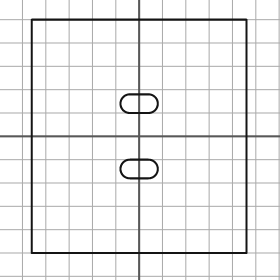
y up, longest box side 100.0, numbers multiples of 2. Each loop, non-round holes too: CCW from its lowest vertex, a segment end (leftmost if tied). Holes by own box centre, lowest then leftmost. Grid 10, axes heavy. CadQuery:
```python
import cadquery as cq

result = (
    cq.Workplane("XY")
    .moveTo(-46.0, -50.0)
    .lineTo(46.0, -50.0)
    .lineTo(46.0, 50.0)
    .lineTo(-46.0, 50.0)
    .close()
    .moveTo(-4.0, -18.0)
    .lineTo(4.0, -18.0)
    .threePointArc((8.0, -14.0), (4.0, -10.0))
    .lineTo(-4.0, -10.0)
    .threePointArc((-8.0, -14.0), (-4.0, -18.0))
    .close()
    .moveTo(-4.0, 10.0)
    .lineTo(4.0, 10.0)
    .threePointArc((8.0, 14.0), (4.0, 18.0))
    .lineTo(-4.0, 18.0)
    .threePointArc((-8.0, 14.0), (-4.0, 10.0))
    .close()
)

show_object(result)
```